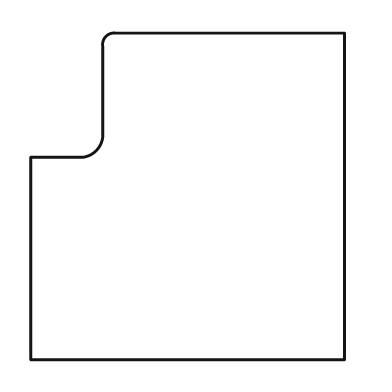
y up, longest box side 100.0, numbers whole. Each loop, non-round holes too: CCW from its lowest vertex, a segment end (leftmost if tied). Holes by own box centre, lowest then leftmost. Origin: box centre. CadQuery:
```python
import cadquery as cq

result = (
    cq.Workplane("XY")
    .moveTo(-48.0, -50.0)
    .lineTo(48.0, -50.0)
    .lineTo(48.0, 50.0)
    .lineTo(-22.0, 50.0)
    .threePointArc((-25.0, 49.0), (-26.0, 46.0))
    .lineTo(-26.0, 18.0)
    .threePointArc((-28.0, 14.0), (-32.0, 12.0))
    .lineTo(-48.0, 12.0)
    .close()
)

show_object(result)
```